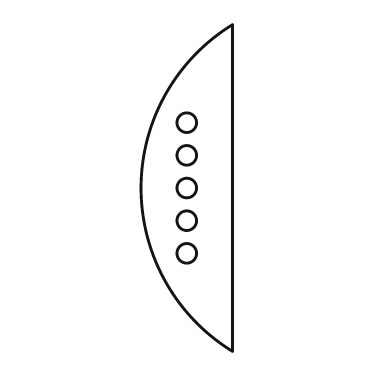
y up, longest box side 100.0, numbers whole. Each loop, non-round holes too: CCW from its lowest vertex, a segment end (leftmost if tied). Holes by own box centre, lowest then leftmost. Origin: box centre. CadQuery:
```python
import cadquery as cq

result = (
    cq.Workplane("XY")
    .moveTo(14.0, -50.0)
    .lineTo(14.0, 50.0)
    .threePointArc((-14.0, 0.0), (14.0, -50.0))
    .close()
    .moveTo(0.0, -20.0)
    .circle(3.0)
    .moveTo(0.0, -10.0)
    .circle(3.0)
    .moveTo(0.0, 0.0)
    .circle(3.0)
    .moveTo(0.0, 10.0)
    .circle(3.0)
    .moveTo(0.0, 20.0)
    .circle(3.0)
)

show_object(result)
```